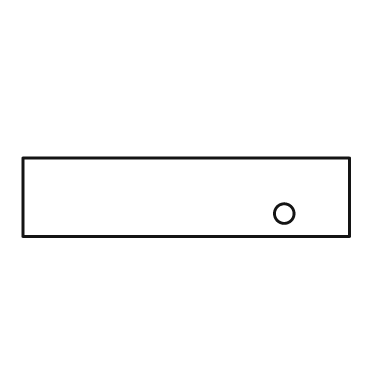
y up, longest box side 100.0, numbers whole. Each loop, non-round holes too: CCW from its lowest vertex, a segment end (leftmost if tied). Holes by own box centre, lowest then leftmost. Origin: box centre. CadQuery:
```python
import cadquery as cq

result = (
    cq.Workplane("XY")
    .moveTo(-50.0, -12.0)
    .lineTo(50.0, -12.0)
    .lineTo(50.0, 12.0)
    .lineTo(-50.0, 12.0)
    .close()
    .moveTo(30.0, -5.0)
    .circle(3.0)
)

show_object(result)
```